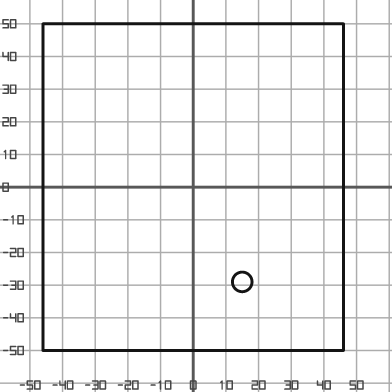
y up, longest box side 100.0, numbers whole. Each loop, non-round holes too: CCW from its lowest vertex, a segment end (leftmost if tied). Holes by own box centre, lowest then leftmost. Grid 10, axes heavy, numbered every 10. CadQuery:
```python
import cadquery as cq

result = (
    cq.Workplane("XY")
    .moveTo(-46.0, -50.0)
    .lineTo(46.0, -50.0)
    .lineTo(46.0, 50.0)
    .lineTo(-46.0, 50.0)
    .close()
    .moveTo(15.0, -29.0)
    .circle(3.0)
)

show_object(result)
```